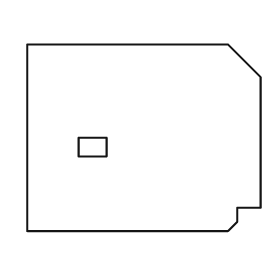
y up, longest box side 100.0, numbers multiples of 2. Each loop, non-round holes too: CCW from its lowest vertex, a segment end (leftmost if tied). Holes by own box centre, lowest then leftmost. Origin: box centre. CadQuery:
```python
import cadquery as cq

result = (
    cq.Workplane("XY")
    .moveTo(-50.0, -40.0)
    .lineTo(36.0, -40.0)
    .lineTo(40.0, -36.0)
    .lineTo(40.0, -30.0)
    .lineTo(50.0, -30.0)
    .lineTo(50.0, 26.0)
    .lineTo(36.0, 40.0)
    .lineTo(-50.0, 40.0)
    .close()
    .moveTo(-28.0, -8.0)
    .lineTo(-16.0, -8.0)
    .lineTo(-16.0, 0.0)
    .lineTo(-28.0, 0.0)
    .close()
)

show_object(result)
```